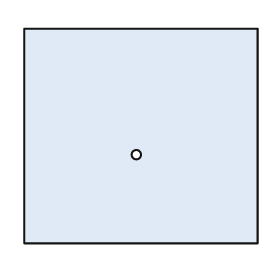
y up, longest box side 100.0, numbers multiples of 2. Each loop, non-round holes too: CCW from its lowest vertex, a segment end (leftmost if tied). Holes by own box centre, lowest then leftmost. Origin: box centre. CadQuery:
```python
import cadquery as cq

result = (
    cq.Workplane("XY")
    .moveTo(-50.0, -46.0)
    .lineTo(50.0, -46.0)
    .lineTo(50.0, 46.0)
    .lineTo(-50.0, 46.0)
    .close()
    .moveTo(-2.0, -8.0)
    .circle(2.0)
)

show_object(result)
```